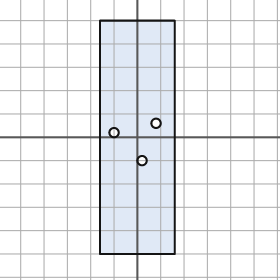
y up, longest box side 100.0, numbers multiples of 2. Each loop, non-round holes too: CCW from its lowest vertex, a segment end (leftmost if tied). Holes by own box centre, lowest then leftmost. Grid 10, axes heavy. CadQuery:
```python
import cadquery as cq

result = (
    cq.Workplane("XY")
    .moveTo(-16.0, -50.0)
    .lineTo(16.0, -50.0)
    .lineTo(16.0, 50.0)
    .lineTo(-16.0, 50.0)
    .close()
    .moveTo(2.0, -10.0)
    .circle(2.0)
    .moveTo(-10.0, 2.0)
    .circle(2.0)
    .moveTo(8.0, 6.0)
    .circle(2.0)
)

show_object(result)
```